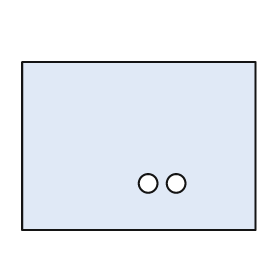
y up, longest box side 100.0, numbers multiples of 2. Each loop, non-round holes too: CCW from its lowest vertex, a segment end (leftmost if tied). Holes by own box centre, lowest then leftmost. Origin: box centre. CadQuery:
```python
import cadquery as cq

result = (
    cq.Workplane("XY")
    .moveTo(-50.0, -36.0)
    .lineTo(50.0, -36.0)
    .lineTo(50.0, 36.0)
    .lineTo(-50.0, 36.0)
    .close()
    .moveTo(4.0, -16.0)
    .circle(4.0)
    .moveTo(16.0, -16.0)
    .circle(4.0)
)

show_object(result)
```